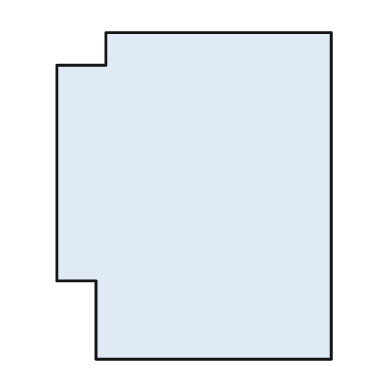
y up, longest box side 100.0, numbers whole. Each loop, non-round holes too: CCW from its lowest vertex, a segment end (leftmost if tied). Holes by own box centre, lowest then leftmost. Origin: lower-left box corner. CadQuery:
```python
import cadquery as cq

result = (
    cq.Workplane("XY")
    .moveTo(12.0, 0.0)
    .lineTo(84.0, 0.0)
    .lineTo(84.0, 100.0)
    .lineTo(15.0, 100.0)
    .lineTo(15.0, 90.0)
    .lineTo(0.0, 90.0)
    .lineTo(0.0, 24.0)
    .lineTo(12.0, 24.0)
    .close()
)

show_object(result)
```